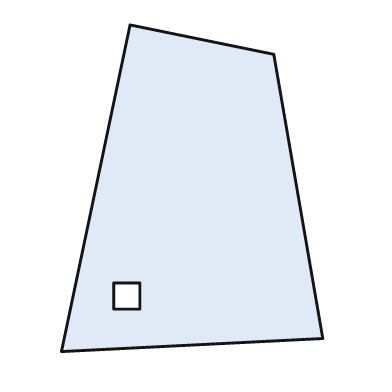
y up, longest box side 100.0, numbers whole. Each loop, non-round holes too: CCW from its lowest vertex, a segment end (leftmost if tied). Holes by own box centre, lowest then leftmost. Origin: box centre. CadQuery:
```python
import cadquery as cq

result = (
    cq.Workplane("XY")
    .moveTo(-40.0, -50.0)
    .lineTo(40.0, -46.0)
    .lineTo(25.0, 41.0)
    .lineTo(-19.0, 50.0)
    .close()
    .moveTo(-24.0, -37.0)
    .lineTo(-16.0, -37.0)
    .lineTo(-16.0, -29.0)
    .lineTo(-24.0, -29.0)
    .close()
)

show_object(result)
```